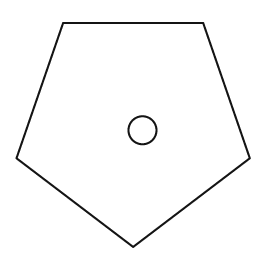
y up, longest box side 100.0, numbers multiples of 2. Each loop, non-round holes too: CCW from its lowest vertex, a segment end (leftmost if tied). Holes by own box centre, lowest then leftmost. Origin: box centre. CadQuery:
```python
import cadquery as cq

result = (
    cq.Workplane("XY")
    .moveTo(0.0, -48.0)
    .lineTo(50.0, -10.0)
    .lineTo(30.0, 48.0)
    .lineTo(-30.0, 48.0)
    .lineTo(-50.0, -10.0)
    .close()
    .moveTo(4.0, 2.0)
    .circle(6.0)
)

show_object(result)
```